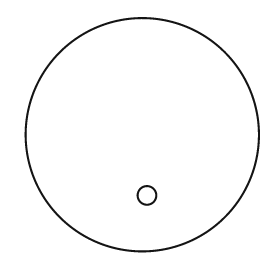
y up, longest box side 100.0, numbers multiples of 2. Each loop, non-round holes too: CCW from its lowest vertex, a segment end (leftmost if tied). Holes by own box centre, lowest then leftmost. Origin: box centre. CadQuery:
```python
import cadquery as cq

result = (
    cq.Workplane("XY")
    .moveTo(0.0, 0.0)
    .circle(50.0)
    .moveTo(2.0, -26.0)
    .circle(4.0)
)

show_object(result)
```